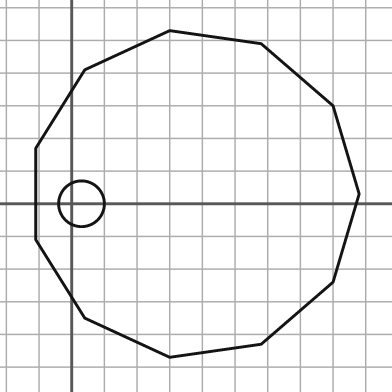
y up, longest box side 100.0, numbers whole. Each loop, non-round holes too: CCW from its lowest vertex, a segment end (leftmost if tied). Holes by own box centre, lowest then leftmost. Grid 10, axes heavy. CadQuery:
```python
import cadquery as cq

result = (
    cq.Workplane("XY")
    .moveTo(30.0, -47.0)
    .lineTo(58.0, -43.0)
    .lineTo(80.0, -24.0)
    .lineTo(88.0, 3.0)
    .lineTo(80.0, 30.0)
    .lineTo(58.0, 49.0)
    .lineTo(30.0, 53.0)
    .lineTo(4.0, 41.0)
    .lineTo(-11.0, 17.0)
    .lineTo(-11.0, -11.0)
    .lineTo(4.0, -35.0)
    .close()
    .moveTo(3.0, 0.0)
    .circle(7.0)
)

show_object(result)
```